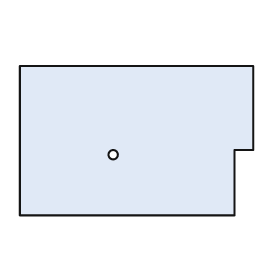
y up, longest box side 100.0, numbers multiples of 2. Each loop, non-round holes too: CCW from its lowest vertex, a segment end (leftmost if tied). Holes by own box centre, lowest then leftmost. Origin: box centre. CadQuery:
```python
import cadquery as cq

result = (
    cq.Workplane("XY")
    .moveTo(-50.0, -32.0)
    .lineTo(42.0, -32.0)
    .lineTo(42.0, -4.0)
    .lineTo(50.0, -4.0)
    .lineTo(50.0, 32.0)
    .lineTo(-50.0, 32.0)
    .close()
    .moveTo(-10.0, -6.0)
    .circle(2.0)
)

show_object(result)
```